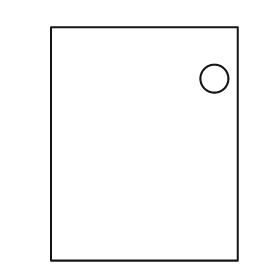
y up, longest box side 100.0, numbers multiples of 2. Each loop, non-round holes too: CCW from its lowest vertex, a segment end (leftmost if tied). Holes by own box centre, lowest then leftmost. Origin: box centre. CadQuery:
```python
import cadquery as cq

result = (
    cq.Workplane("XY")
    .moveTo(-40.0, -50.0)
    .lineTo(40.0, -50.0)
    .lineTo(40.0, 50.0)
    .lineTo(-40.0, 50.0)
    .close()
    .moveTo(30.0, 28.0)
    .circle(6.0)
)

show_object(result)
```